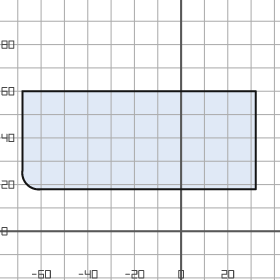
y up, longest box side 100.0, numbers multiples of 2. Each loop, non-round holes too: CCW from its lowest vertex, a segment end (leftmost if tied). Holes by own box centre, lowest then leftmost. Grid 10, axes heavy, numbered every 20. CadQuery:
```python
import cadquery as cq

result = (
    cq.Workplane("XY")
    .moveTo(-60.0, 18.0)
    .lineTo(32.0, 18.0)
    .lineTo(32.0, 60.0)
    .lineTo(-68.0, 60.0)
    .lineTo(-68.0, 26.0)
    .threePointArc((-66.0, 20.0), (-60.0, 18.0))
    .close()
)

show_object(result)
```